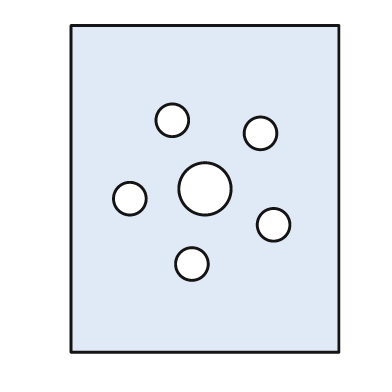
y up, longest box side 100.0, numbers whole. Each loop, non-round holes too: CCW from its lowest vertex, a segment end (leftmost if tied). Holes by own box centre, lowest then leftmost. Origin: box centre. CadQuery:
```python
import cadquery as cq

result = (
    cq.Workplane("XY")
    .moveTo(-41.0, -50.0)
    .lineTo(41.0, -50.0)
    .lineTo(41.0, 50.0)
    .lineTo(-41.0, 50.0)
    .close()
    .moveTo(-4.0, -23.0)
    .circle(5.0)
    .moveTo(21.0, -11.0)
    .circle(5.0)
    .moveTo(-23.0, -3.0)
    .circle(5.0)
    .moveTo(0.0, 0.0)
    .circle(8.0)
    .moveTo(17.0, 17.0)
    .circle(5.0)
    .moveTo(-10.0, 21.0)
    .circle(5.0)
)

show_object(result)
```